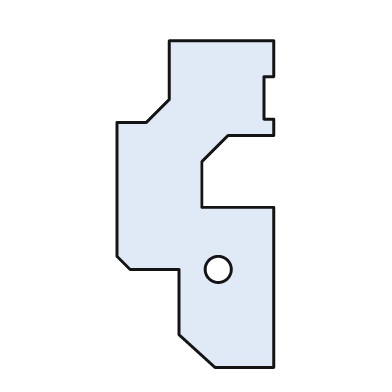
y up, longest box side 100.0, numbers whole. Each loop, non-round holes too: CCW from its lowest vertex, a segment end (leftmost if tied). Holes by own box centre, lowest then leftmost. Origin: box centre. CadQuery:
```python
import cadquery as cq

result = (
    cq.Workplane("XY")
    .moveTo(6.0, -50.0)
    .lineTo(24.0, -50.0)
    .lineTo(24.0, -1.0)
    .lineTo(2.0, -1.0)
    .lineTo(2.0, 13.0)
    .lineTo(10.0, 21.0)
    .lineTo(24.0, 21.0)
    .lineTo(24.0, 26.0)
    .lineTo(21.0, 26.0)
    .lineTo(21.0, 39.0)
    .lineTo(24.0, 39.0)
    .lineTo(24.0, 50.0)
    .lineTo(-8.0, 50.0)
    .lineTo(-8.0, 32.0)
    .lineTo(-15.0, 25.0)
    .lineTo(-24.0, 25.0)
    .lineTo(-24.0, -16.0)
    .lineTo(-20.0, -20.0)
    .lineTo(-5.0, -20.0)
    .lineTo(-5.0, -40.0)
    .close()
    .moveTo(7.0, -20.0)
    .circle(4.0)
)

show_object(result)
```